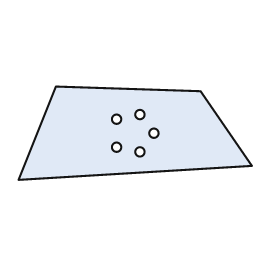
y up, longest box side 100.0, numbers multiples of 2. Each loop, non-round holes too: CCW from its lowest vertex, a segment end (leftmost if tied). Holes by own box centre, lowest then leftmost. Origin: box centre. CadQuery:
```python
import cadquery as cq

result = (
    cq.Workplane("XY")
    .moveTo(-50.0, -20.0)
    .lineTo(50.0, -14.0)
    .lineTo(28.0, 18.0)
    .lineTo(-34.0, 20.0)
    .close()
    .moveTo(2.0, -8.0)
    .circle(2.0)
    .moveTo(-8.0, -6.0)
    .circle(2.0)
    .moveTo(8.0, 0.0)
    .circle(2.0)
    .moveTo(-8.0, 6.0)
    .circle(2.0)
    .moveTo(2.0, 8.0)
    .circle(2.0)
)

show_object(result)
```